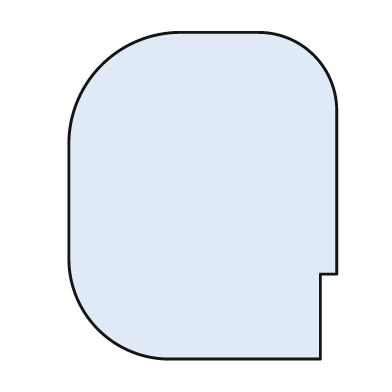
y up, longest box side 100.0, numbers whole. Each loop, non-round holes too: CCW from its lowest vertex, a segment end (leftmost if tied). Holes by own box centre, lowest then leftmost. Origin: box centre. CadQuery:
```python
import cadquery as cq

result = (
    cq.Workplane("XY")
    .moveTo(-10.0, -50.0)
    .lineTo(36.0, -50.0)
    .lineTo(36.0, -24.0)
    .lineTo(41.0, -24.0)
    .lineTo(41.0, 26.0)
    .threePointArc((34.0, 43.0), (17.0, 50.0))
    .lineTo(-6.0, 50.0)
    .threePointArc((-31.0, 40.0), (-41.0, 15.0))
    .lineTo(-41.0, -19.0)
    .threePointArc((-32.0, -41.0), (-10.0, -50.0))
    .close()
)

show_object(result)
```